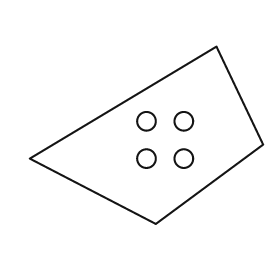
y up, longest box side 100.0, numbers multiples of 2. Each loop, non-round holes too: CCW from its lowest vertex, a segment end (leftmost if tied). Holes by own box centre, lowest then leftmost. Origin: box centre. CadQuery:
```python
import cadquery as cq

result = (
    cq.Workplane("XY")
    .moveTo(4.0, -38.0)
    .lineTo(50.0, -4.0)
    .lineTo(30.0, 38.0)
    .lineTo(-50.0, -10.0)
    .close()
    .moveTo(0.0, -10.0)
    .circle(4.0)
    .moveTo(16.0, -10.0)
    .circle(4.0)
    .moveTo(0.0, 6.0)
    .circle(4.0)
    .moveTo(16.0, 6.0)
    .circle(4.0)
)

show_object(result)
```